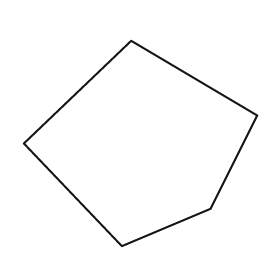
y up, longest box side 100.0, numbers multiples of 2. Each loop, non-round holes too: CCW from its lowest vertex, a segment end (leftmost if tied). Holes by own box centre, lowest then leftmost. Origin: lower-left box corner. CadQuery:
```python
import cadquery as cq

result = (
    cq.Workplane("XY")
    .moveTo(42.0, 0.0)
    .lineTo(80.0, 16.0)
    .lineTo(100.0, 56.0)
    .lineTo(46.0, 88.0)
    .lineTo(0.0, 44.0)
    .close()
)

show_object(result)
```